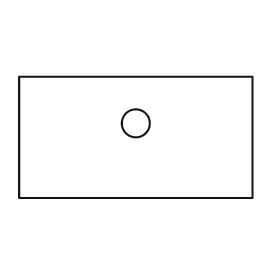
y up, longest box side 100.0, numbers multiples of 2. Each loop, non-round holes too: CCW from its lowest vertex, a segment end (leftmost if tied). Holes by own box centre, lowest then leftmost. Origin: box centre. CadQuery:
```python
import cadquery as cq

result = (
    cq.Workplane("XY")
    .moveTo(-50.0, -26.0)
    .lineTo(50.0, -26.0)
    .lineTo(50.0, 26.0)
    .lineTo(-50.0, 26.0)
    .close()
    .moveTo(0.0, 6.0)
    .circle(6.0)
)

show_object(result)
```